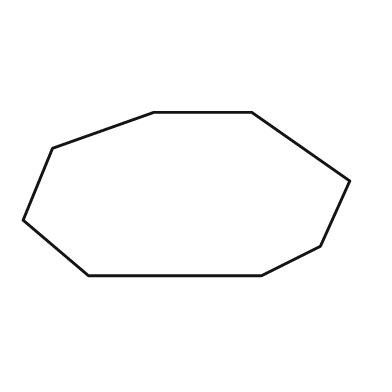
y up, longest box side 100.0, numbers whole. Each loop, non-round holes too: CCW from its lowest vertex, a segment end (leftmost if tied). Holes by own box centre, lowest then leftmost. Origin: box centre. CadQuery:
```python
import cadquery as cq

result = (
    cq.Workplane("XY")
    .moveTo(-30.0, -25.0)
    .lineTo(23.0, -25.0)
    .lineTo(41.0, -16.0)
    .lineTo(50.0, 4.0)
    .lineTo(20.0, 25.0)
    .lineTo(-10.0, 25.0)
    .lineTo(-41.0, 14.0)
    .lineTo(-50.0, -8.0)
    .close()
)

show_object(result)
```